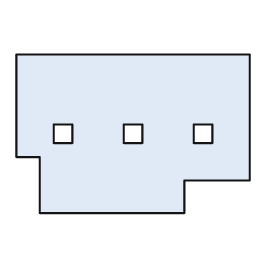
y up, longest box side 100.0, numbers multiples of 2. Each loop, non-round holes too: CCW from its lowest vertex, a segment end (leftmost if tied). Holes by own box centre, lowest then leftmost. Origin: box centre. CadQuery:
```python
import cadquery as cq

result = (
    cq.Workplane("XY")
    .moveTo(-40.0, -34.0)
    .lineTo(22.0, -34.0)
    .lineTo(22.0, -20.0)
    .lineTo(50.0, -20.0)
    .lineTo(50.0, 34.0)
    .lineTo(-50.0, 34.0)
    .lineTo(-50.0, -10.0)
    .lineTo(-40.0, -10.0)
    .close()
    .moveTo(-34.0, -4.0)
    .lineTo(-26.0, -4.0)
    .lineTo(-26.0, 4.0)
    .lineTo(-34.0, 4.0)
    .close()
    .moveTo(-4.0, -4.0)
    .lineTo(4.0, -4.0)
    .lineTo(4.0, 4.0)
    .lineTo(-4.0, 4.0)
    .close()
    .moveTo(26.0, -4.0)
    .lineTo(34.0, -4.0)
    .lineTo(34.0, 4.0)
    .lineTo(26.0, 4.0)
    .close()
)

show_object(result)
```